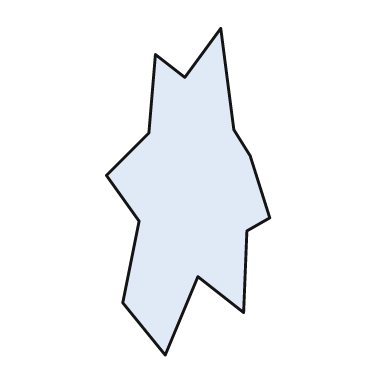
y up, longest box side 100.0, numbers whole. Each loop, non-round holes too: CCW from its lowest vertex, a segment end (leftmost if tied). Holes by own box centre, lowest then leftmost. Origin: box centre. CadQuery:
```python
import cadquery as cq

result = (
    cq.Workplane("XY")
    .moveTo(-7.0, -50.0)
    .lineTo(3.0, -26.0)
    .lineTo(17.0, -37.0)
    .lineTo(18.0, -12.0)
    .lineTo(25.0, -8.0)
    .lineTo(19.0, 11.0)
    .lineTo(14.0, 19.0)
    .lineTo(10.0, 50.0)
    .lineTo(-1.0, 35.0)
    .lineTo(-10.0, 42.0)
    .lineTo(-12.0, 18.0)
    .lineTo(-25.0, 5.0)
    .lineTo(-15.0, -9.0)
    .lineTo(-20.0, -34.0)
    .close()
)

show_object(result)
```